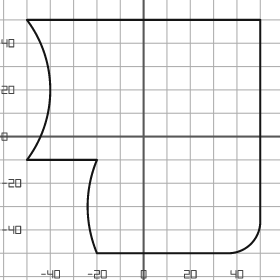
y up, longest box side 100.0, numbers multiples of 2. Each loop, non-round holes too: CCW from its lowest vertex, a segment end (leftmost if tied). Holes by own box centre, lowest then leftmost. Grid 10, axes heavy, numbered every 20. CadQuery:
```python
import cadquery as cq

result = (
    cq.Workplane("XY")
    .moveTo(-20.0, -50.0)
    .lineTo(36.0, -50.0)
    .threePointArc((46.0, -46.0), (50.0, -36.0))
    .lineTo(50.0, 50.0)
    .lineTo(-50.0, 50.0)
    .threePointArc((-40.0, 20.0), (-50.0, -10.0))
    .lineTo(-20.0, -10.0)
    .threePointArc((-24.0, -30.0), (-20.0, -50.0))
    .close()
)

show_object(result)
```